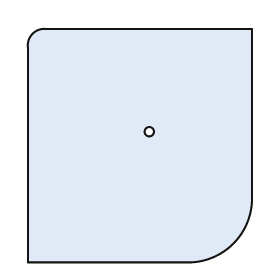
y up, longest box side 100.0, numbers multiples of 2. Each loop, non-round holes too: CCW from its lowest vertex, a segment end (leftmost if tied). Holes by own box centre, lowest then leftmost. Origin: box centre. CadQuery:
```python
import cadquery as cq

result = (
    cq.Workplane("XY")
    .moveTo(-48.0, -50.0)
    .lineTo(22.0, -50.0)
    .threePointArc((40.0, -42.0), (48.0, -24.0))
    .lineTo(48.0, 50.0)
    .lineTo(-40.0, 50.0)
    .threePointArc((-46.0, 48.0), (-48.0, 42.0))
    .close()
    .moveTo(4.0, 6.0)
    .circle(2.0)
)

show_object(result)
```